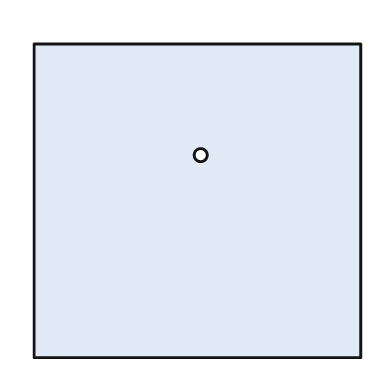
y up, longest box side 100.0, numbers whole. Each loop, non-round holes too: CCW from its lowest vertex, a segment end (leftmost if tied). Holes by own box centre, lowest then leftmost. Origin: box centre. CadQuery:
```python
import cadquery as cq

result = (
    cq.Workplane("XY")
    .moveTo(-50.0, -48.0)
    .lineTo(50.0, -48.0)
    .lineTo(50.0, 48.0)
    .lineTo(-50.0, 48.0)
    .close()
    .moveTo(1.0, 14.0)
    .circle(2.0)
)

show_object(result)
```